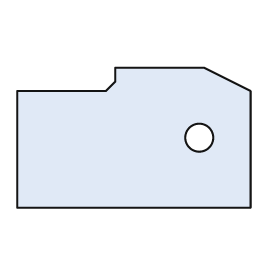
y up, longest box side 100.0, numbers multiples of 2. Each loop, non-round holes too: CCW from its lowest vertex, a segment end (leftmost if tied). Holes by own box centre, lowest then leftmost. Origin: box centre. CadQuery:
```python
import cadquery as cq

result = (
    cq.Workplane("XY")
    .moveTo(-50.0, -30.0)
    .lineTo(50.0, -30.0)
    .lineTo(50.0, 20.0)
    .lineTo(30.0, 30.0)
    .lineTo(-8.0, 30.0)
    .lineTo(-8.0, 24.0)
    .lineTo(-12.0, 20.0)
    .lineTo(-50.0, 20.0)
    .close()
    .moveTo(28.0, 0.0)
    .circle(6.0)
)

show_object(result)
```